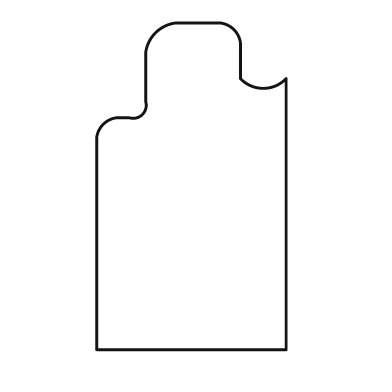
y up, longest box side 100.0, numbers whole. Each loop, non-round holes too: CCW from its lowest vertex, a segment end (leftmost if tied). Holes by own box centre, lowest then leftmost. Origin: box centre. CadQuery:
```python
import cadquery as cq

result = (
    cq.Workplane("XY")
    .moveTo(-29.0, -50.0)
    .lineTo(29.0, -50.0)
    .lineTo(29.0, 33.0)
    .threePointArc((22.0, 30.0), (15.0, 33.0))
    .lineTo(15.0, 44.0)
    .threePointArc((13.0, 48.0), (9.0, 50.0))
    .lineTo(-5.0, 50.0)
    .threePointArc((-11.0, 47.0), (-14.0, 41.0))
    .lineTo(-14.0, 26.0)
    .threePointArc((-15.0, 22.0), (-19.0, 21.0))
    .lineTo(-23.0, 21.0)
    .threePointArc((-27.0, 19.0), (-29.0, 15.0))
    .close()
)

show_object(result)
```